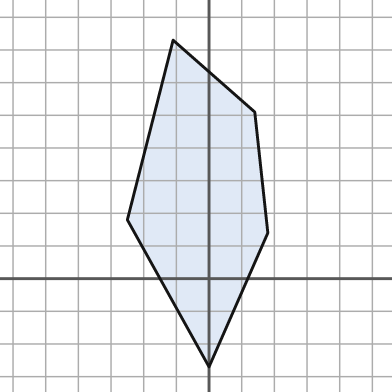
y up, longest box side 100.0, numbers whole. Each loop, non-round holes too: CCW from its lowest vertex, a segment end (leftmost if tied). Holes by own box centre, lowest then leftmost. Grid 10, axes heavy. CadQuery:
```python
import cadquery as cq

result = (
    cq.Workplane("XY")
    .moveTo(0.0, -27.0)
    .lineTo(18.0, 14.0)
    .lineTo(14.0, 51.0)
    .lineTo(-11.0, 73.0)
    .lineTo(-25.0, 18.0)
    .close()
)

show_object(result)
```